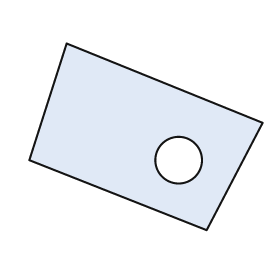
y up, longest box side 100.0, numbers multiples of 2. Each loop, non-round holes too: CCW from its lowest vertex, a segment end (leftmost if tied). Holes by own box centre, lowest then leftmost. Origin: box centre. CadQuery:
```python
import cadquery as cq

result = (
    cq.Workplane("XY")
    .moveTo(26.0, -40.0)
    .lineTo(50.0, 6.0)
    .lineTo(-34.0, 40.0)
    .lineTo(-50.0, -10.0)
    .close()
    .moveTo(14.0, -10.0)
    .circle(10.0)
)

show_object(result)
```